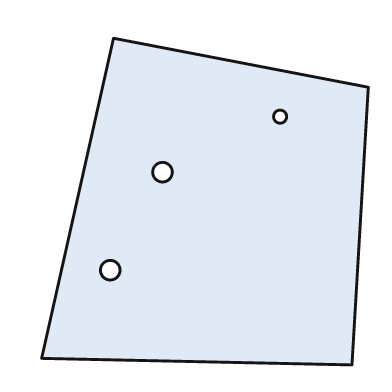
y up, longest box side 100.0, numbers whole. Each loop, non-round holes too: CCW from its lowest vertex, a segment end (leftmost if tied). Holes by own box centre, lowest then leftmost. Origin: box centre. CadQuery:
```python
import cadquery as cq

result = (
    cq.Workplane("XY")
    .moveTo(45.0, -50.0)
    .lineTo(50.0, 35.0)
    .lineTo(-28.0, 50.0)
    .lineTo(-50.0, -48.0)
    .close()
    .moveTo(-29.0, -21.0)
    .circle(3.0)
    .moveTo(-13.0, 9.0)
    .circle(3.0)
    .moveTo(23.0, 26.0)
    .circle(2.0)
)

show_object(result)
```